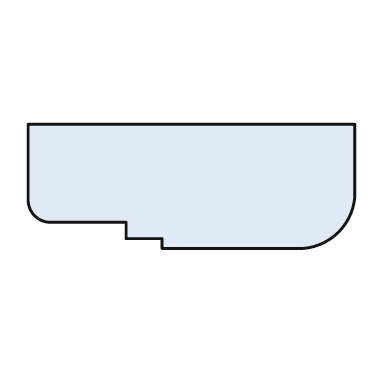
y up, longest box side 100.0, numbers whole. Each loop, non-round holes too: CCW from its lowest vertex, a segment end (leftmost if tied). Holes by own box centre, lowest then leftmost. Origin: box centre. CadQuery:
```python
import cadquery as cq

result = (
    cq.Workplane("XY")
    .moveTo(-9.0, -19.0)
    .lineTo(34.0, -19.0)
    .threePointArc((45.0, -14.0), (50.0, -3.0))
    .lineTo(50.0, 19.0)
    .lineTo(-50.0, 19.0)
    .lineTo(-50.0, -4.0)
    .threePointArc((-48.0, -9.0), (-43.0, -11.0))
    .lineTo(-20.0, -11.0)
    .lineTo(-20.0, -16.0)
    .lineTo(-9.0, -16.0)
    .close()
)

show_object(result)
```